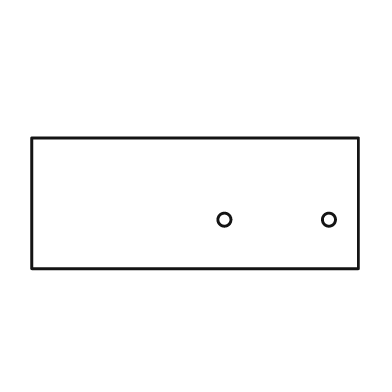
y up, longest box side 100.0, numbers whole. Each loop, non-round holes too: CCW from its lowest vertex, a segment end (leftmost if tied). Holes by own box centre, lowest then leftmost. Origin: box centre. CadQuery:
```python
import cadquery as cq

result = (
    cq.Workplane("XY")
    .moveTo(-50.0, -20.0)
    .lineTo(50.0, -20.0)
    .lineTo(50.0, 20.0)
    .lineTo(-50.0, 20.0)
    .close()
    .moveTo(9.0, -5.0)
    .circle(2.0)
    .moveTo(41.0, -5.0)
    .circle(2.0)
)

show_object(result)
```